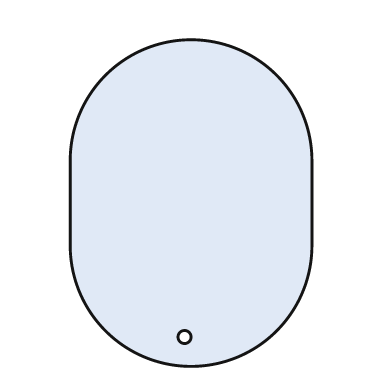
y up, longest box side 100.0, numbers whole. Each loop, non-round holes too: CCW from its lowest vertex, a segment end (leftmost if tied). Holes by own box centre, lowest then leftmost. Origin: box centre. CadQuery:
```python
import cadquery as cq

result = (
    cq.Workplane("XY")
    .moveTo(-37.0, -13.0)
    .threePointArc((0.0, -50.0), (37.0, -13.0))
    .lineTo(37.0, 13.0)
    .threePointArc((0.0, 50.0), (-37.0, 13.0))
    .close()
    .moveTo(-2.0, -41.0)
    .circle(2.0)
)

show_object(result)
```